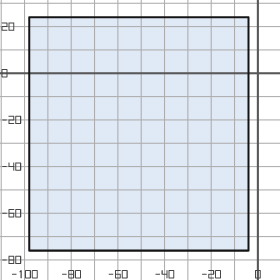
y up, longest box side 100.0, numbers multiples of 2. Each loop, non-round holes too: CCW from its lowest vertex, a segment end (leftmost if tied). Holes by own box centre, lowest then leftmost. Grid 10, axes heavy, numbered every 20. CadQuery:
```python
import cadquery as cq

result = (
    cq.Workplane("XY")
    .moveTo(-98.0, -76.0)
    .lineTo(-4.0, -76.0)
    .lineTo(-4.0, 24.0)
    .lineTo(-98.0, 24.0)
    .close()
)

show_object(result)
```